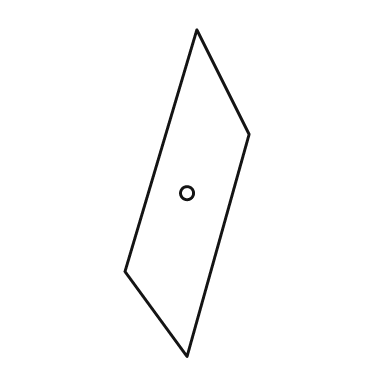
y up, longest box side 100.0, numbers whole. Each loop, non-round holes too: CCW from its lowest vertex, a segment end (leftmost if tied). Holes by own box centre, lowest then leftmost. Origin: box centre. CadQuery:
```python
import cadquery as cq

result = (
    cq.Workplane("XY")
    .moveTo(0.0, -50.0)
    .lineTo(19.0, 18.0)
    .lineTo(3.0, 50.0)
    .lineTo(-19.0, -24.0)
    .close()
    .moveTo(0.0, 0.0)
    .circle(2.0)
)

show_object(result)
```